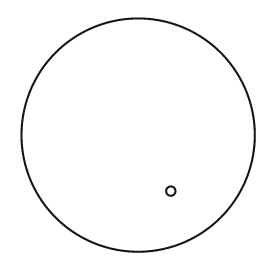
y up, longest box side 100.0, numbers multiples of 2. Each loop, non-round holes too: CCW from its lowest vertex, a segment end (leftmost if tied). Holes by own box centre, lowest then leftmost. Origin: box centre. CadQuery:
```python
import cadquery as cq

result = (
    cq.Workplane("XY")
    .moveTo(0.0, 0.0)
    .circle(50.0)
    .moveTo(14.0, -24.0)
    .circle(2.0)
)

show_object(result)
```